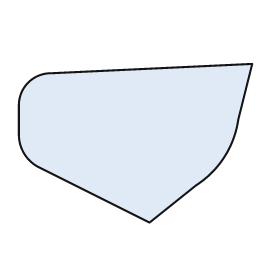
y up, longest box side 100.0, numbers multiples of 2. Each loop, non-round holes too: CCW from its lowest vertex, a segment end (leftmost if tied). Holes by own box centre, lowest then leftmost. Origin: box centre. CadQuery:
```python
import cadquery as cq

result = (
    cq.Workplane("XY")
    .moveTo(6.0, -34.0)
    .lineTo(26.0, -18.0)
    .threePointArc((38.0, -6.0), (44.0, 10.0))
    .lineTo(50.0, 34.0)
    .lineTo(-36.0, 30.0)
    .threePointArc((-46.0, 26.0), (-50.0, 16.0))
    .lineTo(-50.0, 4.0)
    .threePointArc((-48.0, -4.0), (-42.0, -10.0))
    .close()
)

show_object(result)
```